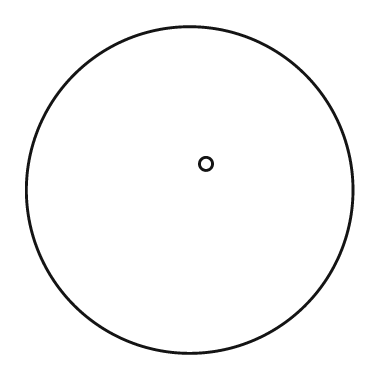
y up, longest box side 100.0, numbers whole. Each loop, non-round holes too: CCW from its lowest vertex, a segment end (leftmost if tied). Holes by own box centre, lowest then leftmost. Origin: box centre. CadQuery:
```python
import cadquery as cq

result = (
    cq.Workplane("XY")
    .moveTo(0.0, 0.0)
    .circle(50.0)
    .moveTo(5.0, 8.0)
    .circle(2.0)
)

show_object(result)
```